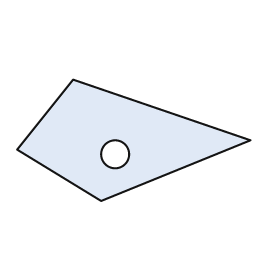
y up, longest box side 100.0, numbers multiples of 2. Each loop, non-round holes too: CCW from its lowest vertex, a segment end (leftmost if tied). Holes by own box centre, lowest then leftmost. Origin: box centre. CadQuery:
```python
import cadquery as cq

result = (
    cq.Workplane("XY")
    .moveTo(-14.0, -26.0)
    .lineTo(50.0, 0.0)
    .lineTo(-26.0, 26.0)
    .lineTo(-50.0, -4.0)
    .close()
    .moveTo(-8.0, -6.0)
    .circle(6.0)
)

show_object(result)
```